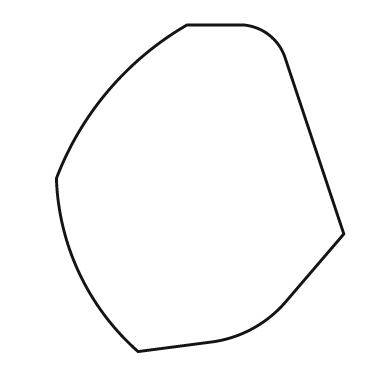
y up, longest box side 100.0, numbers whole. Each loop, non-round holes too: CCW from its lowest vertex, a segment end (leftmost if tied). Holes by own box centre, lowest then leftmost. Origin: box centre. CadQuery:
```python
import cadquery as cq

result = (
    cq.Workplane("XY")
    .moveTo(-19.0, -50.0)
    .lineTo(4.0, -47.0)
    .threePointArc((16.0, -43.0), (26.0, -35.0))
    .lineTo(44.0, -14.0)
    .lineTo(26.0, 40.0)
    .threePointArc((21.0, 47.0), (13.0, 50.0))
    .lineTo(-4.0, 50.0)
    .threePointArc((-28.0, 30.0), (-44.0, 3.0))
    .threePointArc((-37.0, -26.0), (-19.0, -50.0))
    .close()
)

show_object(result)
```